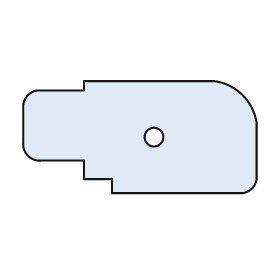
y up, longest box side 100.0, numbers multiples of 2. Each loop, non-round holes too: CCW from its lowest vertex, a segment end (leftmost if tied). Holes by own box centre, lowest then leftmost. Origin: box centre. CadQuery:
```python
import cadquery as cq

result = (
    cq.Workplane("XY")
    .moveTo(-12.0, -24.0)
    .lineTo(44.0, -24.0)
    .threePointArc((48.0, -22.0), (50.0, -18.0))
    .lineTo(50.0, 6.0)
    .threePointArc((44.0, 18.0), (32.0, 24.0))
    .lineTo(-24.0, 24.0)
    .lineTo(-24.0, 20.0)
    .lineTo(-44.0, 20.0)
    .threePointArc((-48.0, 18.0), (-50.0, 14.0))
    .lineTo(-50.0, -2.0)
    .threePointArc((-48.0, -8.0), (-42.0, -10.0))
    .lineTo(-24.0, -10.0)
    .lineTo(-24.0, -18.0)
    .lineTo(-12.0, -18.0)
    .close()
    .moveTo(6.0, 0.0)
    .circle(4.0)
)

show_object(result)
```